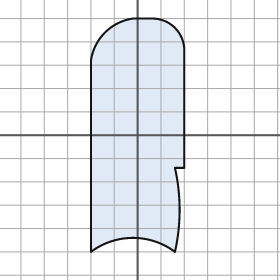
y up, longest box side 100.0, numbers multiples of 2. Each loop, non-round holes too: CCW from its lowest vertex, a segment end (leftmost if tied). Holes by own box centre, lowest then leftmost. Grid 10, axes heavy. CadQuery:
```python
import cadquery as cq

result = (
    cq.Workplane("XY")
    .moveTo(-20.0, -50.0)
    .threePointArc((-2.0, -44.0), (16.0, -50.0))
    .threePointArc((18.0, -32.0), (16.0, -14.0))
    .lineTo(20.0, -14.0)
    .lineTo(20.0, 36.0)
    .threePointArc((16.0, 46.0), (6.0, 50.0))
    .lineTo(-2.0, 50.0)
    .threePointArc((-14.0, 44.0), (-20.0, 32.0))
    .close()
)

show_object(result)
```